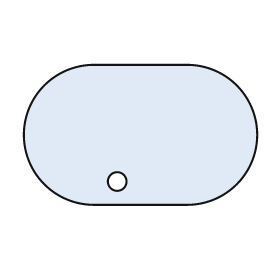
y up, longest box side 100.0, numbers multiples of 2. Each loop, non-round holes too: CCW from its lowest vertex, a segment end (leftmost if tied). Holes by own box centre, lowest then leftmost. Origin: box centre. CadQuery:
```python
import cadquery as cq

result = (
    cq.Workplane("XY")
    .moveTo(-20.0, -30.0)
    .lineTo(20.0, -30.0)
    .threePointArc((50.0, 0.0), (20.0, 30.0))
    .lineTo(-20.0, 30.0)
    .threePointArc((-50.0, 0.0), (-20.0, -30.0))
    .close()
    .moveTo(-10.0, -20.0)
    .circle(4.0)
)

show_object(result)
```